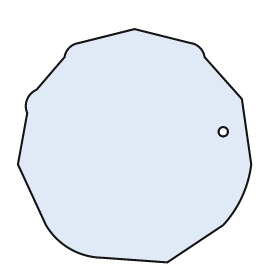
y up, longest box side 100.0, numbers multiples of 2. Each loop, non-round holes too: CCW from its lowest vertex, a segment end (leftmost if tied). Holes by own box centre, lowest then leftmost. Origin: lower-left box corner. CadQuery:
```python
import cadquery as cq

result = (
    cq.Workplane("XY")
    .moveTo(64.0, 0.0)
    .lineTo(88.0, 16.0)
    .threePointArc((96.0, 28.0), (100.0, 42.0))
    .lineTo(96.0, 70.0)
    .lineTo(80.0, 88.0)
    .threePointArc((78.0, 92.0), (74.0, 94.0))
    .lineTo(50.0, 100.0)
    .lineTo(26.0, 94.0)
    .threePointArc((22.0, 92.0), (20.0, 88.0))
    .lineTo(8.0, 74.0)
    .threePointArc((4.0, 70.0), (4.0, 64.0))
    .lineTo(0.0, 42.0)
    .lineTo(12.0, 16.0)
    .threePointArc((22.0, 6.0), (36.0, 2.0))
    .close()
    .moveTo(88.0, 56.0)
    .circle(2.0)
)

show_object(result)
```